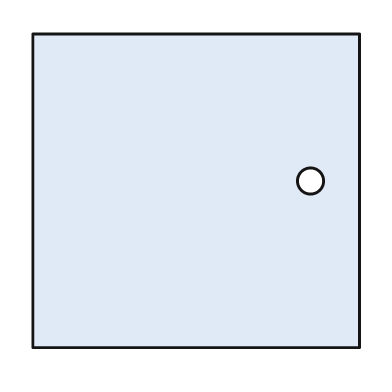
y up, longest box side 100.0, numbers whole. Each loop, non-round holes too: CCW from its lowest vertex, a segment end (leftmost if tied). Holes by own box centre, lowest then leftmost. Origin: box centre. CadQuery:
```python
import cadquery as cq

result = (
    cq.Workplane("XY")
    .moveTo(-50.0, -48.0)
    .lineTo(50.0, -48.0)
    .lineTo(50.0, 48.0)
    .lineTo(-50.0, 48.0)
    .close()
    .moveTo(35.0, 3.0)
    .circle(4.0)
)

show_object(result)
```